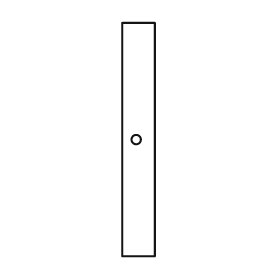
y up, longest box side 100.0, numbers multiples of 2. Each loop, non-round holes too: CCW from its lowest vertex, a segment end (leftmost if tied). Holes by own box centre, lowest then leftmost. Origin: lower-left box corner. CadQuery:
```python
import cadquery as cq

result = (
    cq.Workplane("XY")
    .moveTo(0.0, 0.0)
    .lineTo(14.0, 0.0)
    .lineTo(14.0, 100.0)
    .lineTo(0.0, 100.0)
    .close()
    .moveTo(6.0, 50.0)
    .circle(2.0)
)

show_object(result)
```